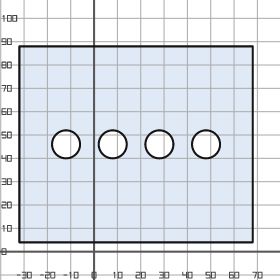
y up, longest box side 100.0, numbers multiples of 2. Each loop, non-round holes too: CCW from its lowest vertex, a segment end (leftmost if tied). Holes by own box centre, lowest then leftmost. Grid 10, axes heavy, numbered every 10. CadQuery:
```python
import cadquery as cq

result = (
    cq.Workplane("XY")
    .moveTo(-32.0, 4.0)
    .lineTo(68.0, 4.0)
    .lineTo(68.0, 88.0)
    .lineTo(-32.0, 88.0)
    .close()
    .moveTo(-12.0, 46.0)
    .circle(6.0)
    .moveTo(8.0, 46.0)
    .circle(6.0)
    .moveTo(28.0, 46.0)
    .circle(6.0)
    .moveTo(48.0, 46.0)
    .circle(6.0)
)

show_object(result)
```